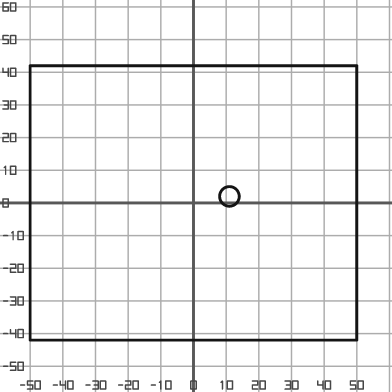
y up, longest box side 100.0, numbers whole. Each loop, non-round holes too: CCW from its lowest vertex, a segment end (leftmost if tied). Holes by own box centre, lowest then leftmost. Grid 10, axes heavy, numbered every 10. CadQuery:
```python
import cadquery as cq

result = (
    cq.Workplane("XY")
    .moveTo(-50.0, -42.0)
    .lineTo(50.0, -42.0)
    .lineTo(50.0, 42.0)
    .lineTo(-50.0, 42.0)
    .close()
    .moveTo(11.0, 2.0)
    .circle(3.0)
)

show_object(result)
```